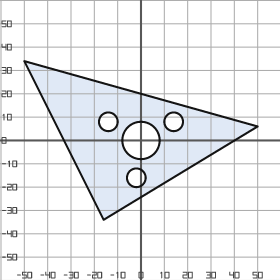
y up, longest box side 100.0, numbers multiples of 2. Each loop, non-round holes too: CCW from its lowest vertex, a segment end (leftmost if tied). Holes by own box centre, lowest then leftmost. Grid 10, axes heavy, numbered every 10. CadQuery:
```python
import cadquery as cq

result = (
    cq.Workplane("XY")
    .moveTo(-16.0, -34.0)
    .lineTo(50.0, 6.0)
    .lineTo(-50.0, 34.0)
    .close()
    .moveTo(-2.0, -16.0)
    .circle(4.0)
    .moveTo(0.0, 0.0)
    .circle(8.0)
    .moveTo(-14.0, 8.0)
    .circle(4.0)
    .moveTo(14.0, 8.0)
    .circle(4.0)
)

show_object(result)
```